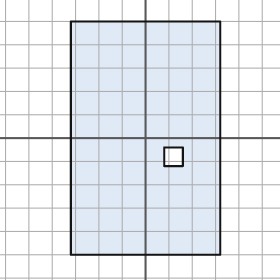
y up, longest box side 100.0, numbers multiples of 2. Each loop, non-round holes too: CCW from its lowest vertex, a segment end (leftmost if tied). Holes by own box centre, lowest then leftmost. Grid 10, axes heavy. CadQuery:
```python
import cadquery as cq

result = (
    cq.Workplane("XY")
    .moveTo(-32.0, -50.0)
    .lineTo(32.0, -50.0)
    .lineTo(32.0, 50.0)
    .lineTo(-32.0, 50.0)
    .close()
    .moveTo(8.0, -12.0)
    .lineTo(16.0, -12.0)
    .lineTo(16.0, -4.0)
    .lineTo(8.0, -4.0)
    .close()
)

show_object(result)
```